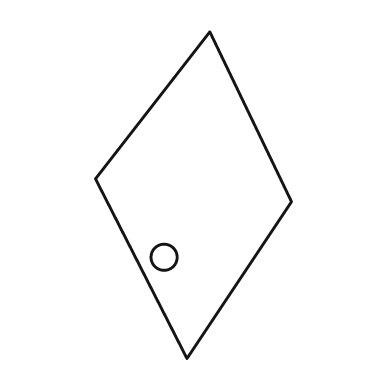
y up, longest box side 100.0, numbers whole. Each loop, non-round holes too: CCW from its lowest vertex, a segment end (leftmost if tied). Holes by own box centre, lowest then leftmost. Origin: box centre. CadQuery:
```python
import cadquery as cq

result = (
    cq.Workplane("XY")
    .moveTo(-2.0, -50.0)
    .lineTo(30.0, -2.0)
    .lineTo(5.0, 50.0)
    .lineTo(-30.0, 5.0)
    .close()
    .moveTo(-9.0, -19.0)
    .circle(4.0)
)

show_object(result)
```